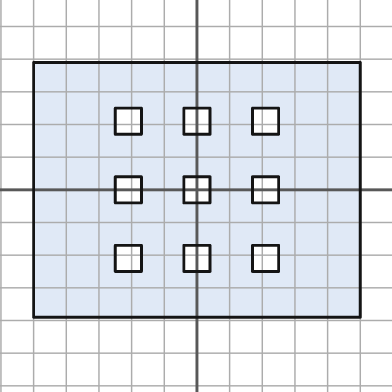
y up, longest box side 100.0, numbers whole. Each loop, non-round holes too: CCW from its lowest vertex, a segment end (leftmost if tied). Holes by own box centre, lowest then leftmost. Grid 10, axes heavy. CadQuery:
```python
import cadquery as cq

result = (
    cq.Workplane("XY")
    .moveTo(-50.0, -39.0)
    .lineTo(50.0, -39.0)
    .lineTo(50.0, 39.0)
    .lineTo(-50.0, 39.0)
    .close()
    .moveTo(-25.0, -25.0)
    .lineTo(-17.0, -25.0)
    .lineTo(-17.0, -17.0)
    .lineTo(-25.0, -17.0)
    .close()
    .moveTo(-4.0, -25.0)
    .lineTo(4.0, -25.0)
    .lineTo(4.0, -17.0)
    .lineTo(-4.0, -17.0)
    .close()
    .moveTo(17.0, -25.0)
    .lineTo(25.0, -25.0)
    .lineTo(25.0, -17.0)
    .lineTo(17.0, -17.0)
    .close()
    .moveTo(-25.0, -4.0)
    .lineTo(-17.0, -4.0)
    .lineTo(-17.0, 4.0)
    .lineTo(-25.0, 4.0)
    .close()
    .moveTo(-4.0, -4.0)
    .lineTo(4.0, -4.0)
    .lineTo(4.0, 4.0)
    .lineTo(-4.0, 4.0)
    .close()
    .moveTo(17.0, -4.0)
    .lineTo(25.0, -4.0)
    .lineTo(25.0, 4.0)
    .lineTo(17.0, 4.0)
    .close()
    .moveTo(-25.0, 17.0)
    .lineTo(-17.0, 17.0)
    .lineTo(-17.0, 25.0)
    .lineTo(-25.0, 25.0)
    .close()
    .moveTo(-4.0, 17.0)
    .lineTo(4.0, 17.0)
    .lineTo(4.0, 25.0)
    .lineTo(-4.0, 25.0)
    .close()
    .moveTo(17.0, 17.0)
    .lineTo(25.0, 17.0)
    .lineTo(25.0, 25.0)
    .lineTo(17.0, 25.0)
    .close()
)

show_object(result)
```